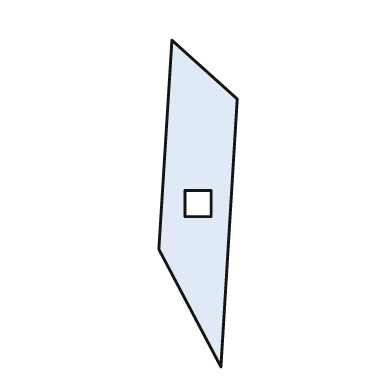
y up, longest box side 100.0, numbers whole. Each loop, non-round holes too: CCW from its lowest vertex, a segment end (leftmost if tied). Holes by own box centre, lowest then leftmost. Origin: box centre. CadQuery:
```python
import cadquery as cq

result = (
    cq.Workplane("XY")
    .moveTo(7.0, -50.0)
    .lineTo(12.0, 32.0)
    .lineTo(-8.0, 50.0)
    .lineTo(-12.0, -14.0)
    .close()
    .moveTo(-4.0, -4.0)
    .lineTo(4.0, -4.0)
    .lineTo(4.0, 4.0)
    .lineTo(-4.0, 4.0)
    .close()
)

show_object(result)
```